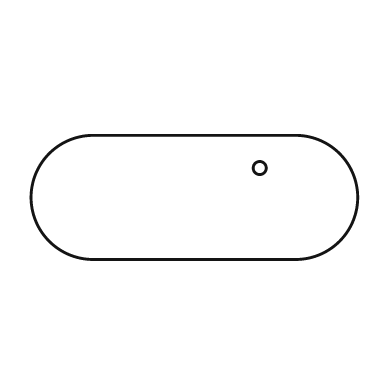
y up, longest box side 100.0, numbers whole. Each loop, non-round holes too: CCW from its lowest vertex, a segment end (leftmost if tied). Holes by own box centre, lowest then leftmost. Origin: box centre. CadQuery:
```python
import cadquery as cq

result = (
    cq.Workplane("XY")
    .moveTo(-31.0, -19.0)
    .lineTo(31.0, -19.0)
    .threePointArc((50.0, 0.0), (31.0, 19.0))
    .lineTo(-31.0, 19.0)
    .threePointArc((-50.0, 0.0), (-31.0, -19.0))
    .close()
    .moveTo(20.0, 9.0)
    .circle(2.0)
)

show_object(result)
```